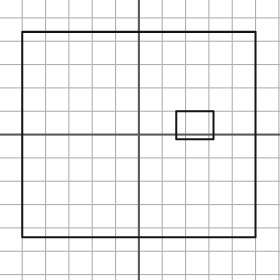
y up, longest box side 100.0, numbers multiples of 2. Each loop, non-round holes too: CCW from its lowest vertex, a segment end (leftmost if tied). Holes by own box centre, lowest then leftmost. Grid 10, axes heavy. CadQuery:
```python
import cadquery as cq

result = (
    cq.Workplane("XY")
    .moveTo(-50.0, -44.0)
    .lineTo(50.0, -44.0)
    .lineTo(50.0, 44.0)
    .lineTo(-50.0, 44.0)
    .close()
    .moveTo(16.0, -2.0)
    .lineTo(32.0, -2.0)
    .lineTo(32.0, 10.0)
    .lineTo(16.0, 10.0)
    .close()
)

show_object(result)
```